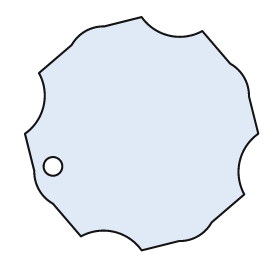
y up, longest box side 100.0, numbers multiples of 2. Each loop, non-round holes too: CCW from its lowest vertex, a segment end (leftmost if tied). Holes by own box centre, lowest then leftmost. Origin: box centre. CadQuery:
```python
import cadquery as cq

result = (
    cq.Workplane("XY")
    .moveTo(0.0, -50.0)
    .lineTo(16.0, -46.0)
    .threePointArc((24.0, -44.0), (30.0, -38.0))
    .lineTo(44.0, -26.0)
    .threePointArc((42.0, -12.0), (50.0, 0.0))
    .lineTo(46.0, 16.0)
    .threePointArc((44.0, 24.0), (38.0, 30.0))
    .lineTo(26.0, 44.0)
    .threePointArc((12.0, 42.0), (0.0, 50.0))
    .lineTo(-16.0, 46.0)
    .threePointArc((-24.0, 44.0), (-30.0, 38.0))
    .lineTo(-44.0, 26.0)
    .threePointArc((-42.0, 12.0), (-50.0, 0.0))
    .lineTo(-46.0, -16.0)
    .threePointArc((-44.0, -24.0), (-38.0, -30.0))
    .lineTo(-26.0, -44.0)
    .threePointArc((-12.0, -42.0), (0.0, -50.0))
    .close()
    .moveTo(-38.0, -14.0)
    .circle(4.0)
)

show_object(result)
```